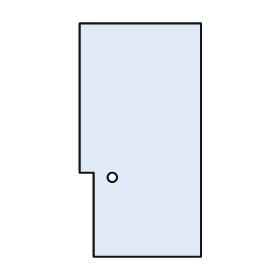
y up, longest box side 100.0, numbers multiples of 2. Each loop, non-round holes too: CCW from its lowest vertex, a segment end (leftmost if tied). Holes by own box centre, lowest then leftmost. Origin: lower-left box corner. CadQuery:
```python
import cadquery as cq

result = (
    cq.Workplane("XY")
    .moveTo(6.0, 0.0)
    .lineTo(52.0, 0.0)
    .lineTo(52.0, 100.0)
    .lineTo(0.0, 100.0)
    .lineTo(0.0, 36.0)
    .lineTo(6.0, 36.0)
    .close()
    .moveTo(14.0, 34.0)
    .circle(2.0)
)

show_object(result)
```